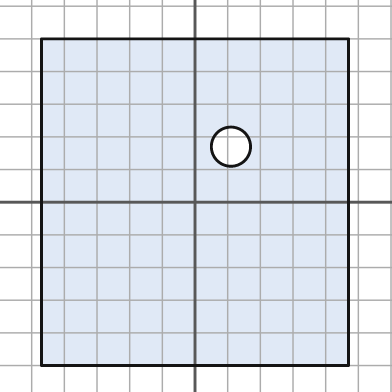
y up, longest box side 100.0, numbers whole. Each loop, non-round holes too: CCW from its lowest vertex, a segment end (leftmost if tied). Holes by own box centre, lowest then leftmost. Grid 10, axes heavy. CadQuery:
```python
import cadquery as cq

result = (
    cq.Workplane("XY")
    .moveTo(-47.0, -50.0)
    .lineTo(47.0, -50.0)
    .lineTo(47.0, 50.0)
    .lineTo(-47.0, 50.0)
    .close()
    .moveTo(11.0, 17.0)
    .circle(6.0)
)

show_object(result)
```